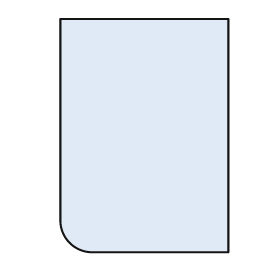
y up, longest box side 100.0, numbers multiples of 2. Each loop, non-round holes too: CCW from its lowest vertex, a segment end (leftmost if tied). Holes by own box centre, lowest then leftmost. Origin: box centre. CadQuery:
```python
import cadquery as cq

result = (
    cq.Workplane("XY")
    .moveTo(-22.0, -50.0)
    .lineTo(36.0, -50.0)
    .lineTo(36.0, 50.0)
    .lineTo(-36.0, 50.0)
    .lineTo(-36.0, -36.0)
    .threePointArc((-32.0, -46.0), (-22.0, -50.0))
    .close()
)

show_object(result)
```